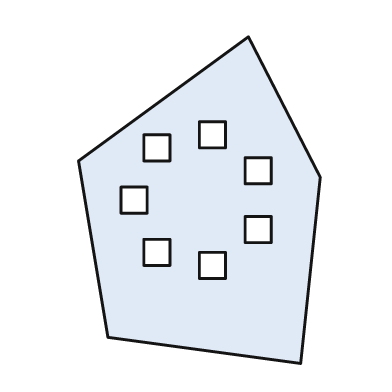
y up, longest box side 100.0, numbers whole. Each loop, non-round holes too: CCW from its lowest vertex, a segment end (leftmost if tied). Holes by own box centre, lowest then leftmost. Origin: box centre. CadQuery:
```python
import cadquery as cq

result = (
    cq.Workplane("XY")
    .moveTo(31.0, -50.0)
    .lineTo(37.0, 7.0)
    .lineTo(15.0, 50.0)
    .lineTo(-37.0, 12.0)
    .lineTo(-28.0, -42.0)
    .close()
    .moveTo(0.0, -24.0)
    .lineTo(8.0, -24.0)
    .lineTo(8.0, -16.0)
    .lineTo(0.0, -16.0)
    .close()
    .moveTo(-17.0, -20.0)
    .lineTo(-9.0, -20.0)
    .lineTo(-9.0, -12.0)
    .lineTo(-17.0, -12.0)
    .close()
    .moveTo(14.0, -13.0)
    .lineTo(22.0, -13.0)
    .lineTo(22.0, -5.0)
    .lineTo(14.0, -5.0)
    .close()
    .moveTo(-24.0, -4.0)
    .lineTo(-16.0, -4.0)
    .lineTo(-16.0, 4.0)
    .lineTo(-24.0, 4.0)
    .close()
    .moveTo(14.0, 5.0)
    .lineTo(22.0, 5.0)
    .lineTo(22.0, 13.0)
    .lineTo(14.0, 13.0)
    .close()
    .moveTo(-17.0, 12.0)
    .lineTo(-9.0, 12.0)
    .lineTo(-9.0, 20.0)
    .lineTo(-17.0, 20.0)
    .close()
    .moveTo(0.0, 16.0)
    .lineTo(8.0, 16.0)
    .lineTo(8.0, 24.0)
    .lineTo(0.0, 24.0)
    .close()
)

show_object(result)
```